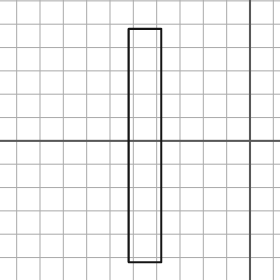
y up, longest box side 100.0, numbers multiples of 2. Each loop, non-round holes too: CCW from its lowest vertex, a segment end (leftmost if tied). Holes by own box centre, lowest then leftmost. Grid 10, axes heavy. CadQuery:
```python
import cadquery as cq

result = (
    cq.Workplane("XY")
    .moveTo(-52.0, -52.0)
    .lineTo(-38.0, -52.0)
    .lineTo(-38.0, 48.0)
    .lineTo(-52.0, 48.0)
    .close()
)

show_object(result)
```